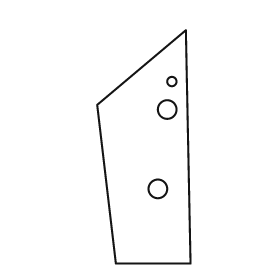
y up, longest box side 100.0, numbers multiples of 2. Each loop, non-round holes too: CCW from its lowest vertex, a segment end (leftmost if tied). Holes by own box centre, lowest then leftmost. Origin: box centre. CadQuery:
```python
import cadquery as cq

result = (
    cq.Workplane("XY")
    .moveTo(-12.0, -50.0)
    .lineTo(20.0, -50.0)
    .lineTo(18.0, 50.0)
    .lineTo(-20.0, 18.0)
    .close()
    .moveTo(6.0, -18.0)
    .circle(4.0)
    .moveTo(10.0, 16.0)
    .circle(4.0)
    .moveTo(12.0, 28.0)
    .circle(2.0)
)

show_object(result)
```